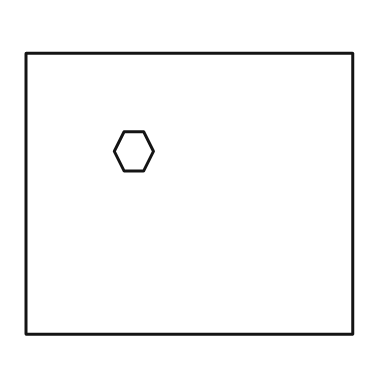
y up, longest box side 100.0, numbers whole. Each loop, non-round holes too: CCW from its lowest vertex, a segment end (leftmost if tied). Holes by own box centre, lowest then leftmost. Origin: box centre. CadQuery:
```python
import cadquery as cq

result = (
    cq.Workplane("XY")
    .moveTo(-50.0, -43.0)
    .lineTo(50.0, -43.0)
    .lineTo(50.0, 43.0)
    .lineTo(-50.0, 43.0)
    .close()
    .moveTo(-20.0, 7.0)
    .lineTo(-14.0, 7.0)
    .lineTo(-11.0, 13.0)
    .lineTo(-14.0, 19.0)
    .lineTo(-20.0, 19.0)
    .lineTo(-23.0, 13.0)
    .close()
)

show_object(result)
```